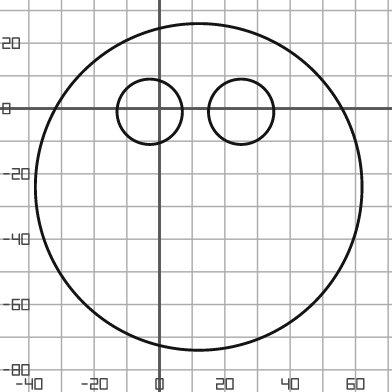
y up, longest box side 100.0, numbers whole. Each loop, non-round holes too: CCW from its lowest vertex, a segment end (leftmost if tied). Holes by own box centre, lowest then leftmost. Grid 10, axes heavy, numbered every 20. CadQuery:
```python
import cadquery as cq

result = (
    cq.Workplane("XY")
    .moveTo(12.0, -24.0)
    .circle(50.0)
    .moveTo(-3.0, -1.0)
    .circle(10.0)
    .moveTo(25.0, -1.0)
    .circle(10.0)
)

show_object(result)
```